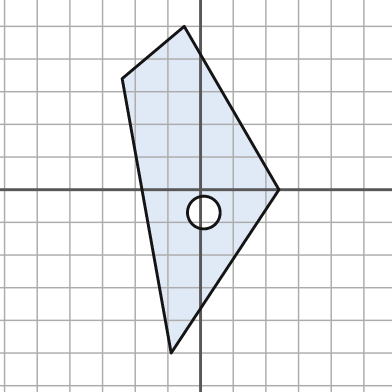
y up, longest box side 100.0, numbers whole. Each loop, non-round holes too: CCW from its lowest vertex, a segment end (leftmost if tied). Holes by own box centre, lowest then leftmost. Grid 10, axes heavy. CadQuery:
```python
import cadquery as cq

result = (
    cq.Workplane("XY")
    .moveTo(-9.0, -50.0)
    .lineTo(24.0, 0.0)
    .lineTo(-5.0, 50.0)
    .lineTo(-24.0, 34.0)
    .close()
    .moveTo(1.0, -7.0)
    .circle(5.0)
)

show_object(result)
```